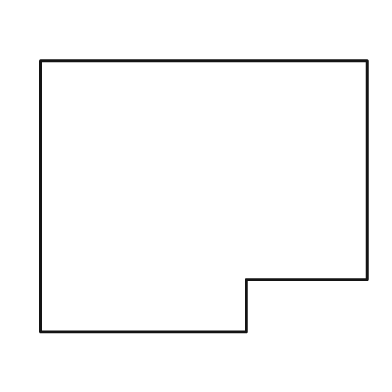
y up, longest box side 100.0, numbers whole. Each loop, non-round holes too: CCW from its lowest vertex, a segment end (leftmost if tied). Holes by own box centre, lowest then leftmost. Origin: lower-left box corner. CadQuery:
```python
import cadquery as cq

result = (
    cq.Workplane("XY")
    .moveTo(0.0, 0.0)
    .lineTo(63.0, 0.0)
    .lineTo(63.0, 16.0)
    .lineTo(100.0, 16.0)
    .lineTo(100.0, 83.0)
    .lineTo(0.0, 83.0)
    .close()
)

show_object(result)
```